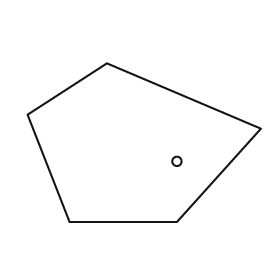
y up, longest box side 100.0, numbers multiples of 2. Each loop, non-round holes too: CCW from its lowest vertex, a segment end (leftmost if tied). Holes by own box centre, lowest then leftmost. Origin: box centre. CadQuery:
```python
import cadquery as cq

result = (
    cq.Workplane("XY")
    .moveTo(-32.0, -34.0)
    .lineTo(14.0, -34.0)
    .lineTo(50.0, 6.0)
    .lineTo(-16.0, 34.0)
    .lineTo(-50.0, 12.0)
    .close()
    .moveTo(14.0, -8.0)
    .circle(2.0)
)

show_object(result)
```